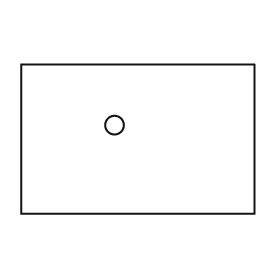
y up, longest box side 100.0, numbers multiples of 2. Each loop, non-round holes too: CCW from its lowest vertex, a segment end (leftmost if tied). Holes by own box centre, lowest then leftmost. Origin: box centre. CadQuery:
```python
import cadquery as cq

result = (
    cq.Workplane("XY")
    .moveTo(-50.0, -32.0)
    .lineTo(50.0, -32.0)
    .lineTo(50.0, 32.0)
    .lineTo(-50.0, 32.0)
    .close()
    .moveTo(-10.0, 6.0)
    .circle(4.0)
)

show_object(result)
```